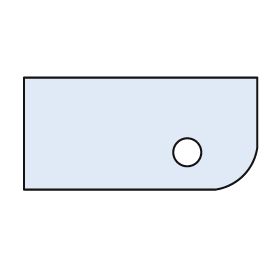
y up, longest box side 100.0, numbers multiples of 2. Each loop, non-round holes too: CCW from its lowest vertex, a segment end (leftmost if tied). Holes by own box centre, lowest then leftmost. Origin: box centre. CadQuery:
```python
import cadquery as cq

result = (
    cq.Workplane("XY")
    .moveTo(-50.0, -24.0)
    .lineTo(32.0, -24.0)
    .threePointArc((44.0, -18.0), (50.0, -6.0))
    .lineTo(50.0, 24.0)
    .lineTo(-50.0, 24.0)
    .close()
    .moveTo(20.0, -8.0)
    .circle(6.0)
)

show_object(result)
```